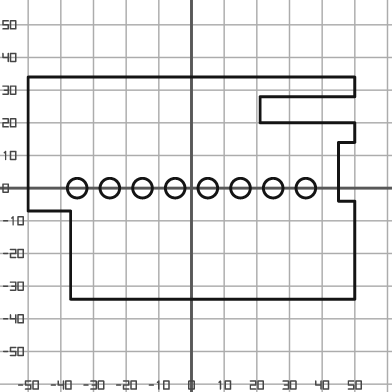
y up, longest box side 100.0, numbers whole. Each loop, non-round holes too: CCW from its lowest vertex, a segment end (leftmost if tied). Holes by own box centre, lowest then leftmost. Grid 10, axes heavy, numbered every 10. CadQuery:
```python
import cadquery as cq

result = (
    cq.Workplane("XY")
    .moveTo(-37.0, -34.0)
    .lineTo(50.0, -34.0)
    .lineTo(50.0, -4.0)
    .lineTo(45.0, -4.0)
    .lineTo(45.0, 14.0)
    .lineTo(50.0, 14.0)
    .lineTo(50.0, 20.0)
    .lineTo(21.0, 20.0)
    .lineTo(21.0, 28.0)
    .lineTo(50.0, 28.0)
    .lineTo(50.0, 34.0)
    .lineTo(-50.0, 34.0)
    .lineTo(-50.0, -7.0)
    .lineTo(-37.0, -7.0)
    .close()
    .moveTo(-35.0, 0.0)
    .circle(3.0)
    .moveTo(-25.0, 0.0)
    .circle(3.0)
    .moveTo(-15.0, 0.0)
    .circle(3.0)
    .moveTo(-5.0, 0.0)
    .circle(3.0)
    .moveTo(5.0, 0.0)
    .circle(3.0)
    .moveTo(15.0, 0.0)
    .circle(3.0)
    .moveTo(25.0, 0.0)
    .circle(3.0)
    .moveTo(35.0, 0.0)
    .circle(3.0)
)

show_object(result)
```